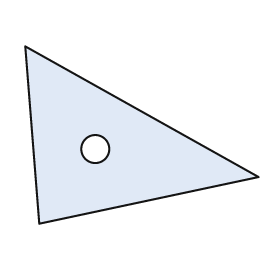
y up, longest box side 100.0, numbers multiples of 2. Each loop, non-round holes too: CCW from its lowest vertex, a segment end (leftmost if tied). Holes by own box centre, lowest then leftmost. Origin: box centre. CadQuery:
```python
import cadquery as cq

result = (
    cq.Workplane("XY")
    .moveTo(-44.0, -38.0)
    .lineTo(50.0, -18.0)
    .lineTo(-50.0, 38.0)
    .close()
    .moveTo(-20.0, -6.0)
    .circle(6.0)
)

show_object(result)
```